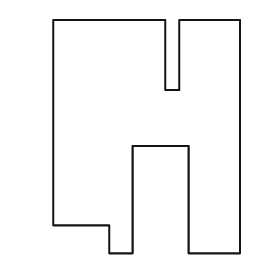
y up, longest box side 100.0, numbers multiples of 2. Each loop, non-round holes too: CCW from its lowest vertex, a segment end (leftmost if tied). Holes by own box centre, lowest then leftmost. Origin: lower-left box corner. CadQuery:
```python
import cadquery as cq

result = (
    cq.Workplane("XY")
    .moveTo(24.0, 0.0)
    .lineTo(34.0, 0.0)
    .lineTo(34.0, 46.0)
    .lineTo(58.0, 46.0)
    .lineTo(58.0, 0.0)
    .lineTo(80.0, 0.0)
    .lineTo(80.0, 100.0)
    .lineTo(54.0, 100.0)
    .lineTo(54.0, 70.0)
    .lineTo(48.0, 70.0)
    .lineTo(48.0, 100.0)
    .lineTo(0.0, 100.0)
    .lineTo(0.0, 12.0)
    .lineTo(24.0, 12.0)
    .close()
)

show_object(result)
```